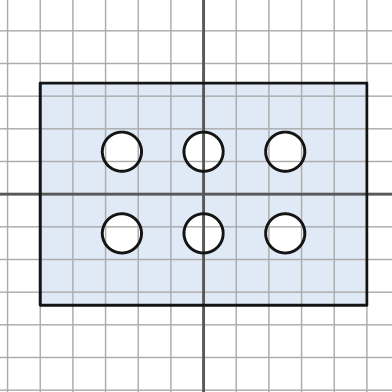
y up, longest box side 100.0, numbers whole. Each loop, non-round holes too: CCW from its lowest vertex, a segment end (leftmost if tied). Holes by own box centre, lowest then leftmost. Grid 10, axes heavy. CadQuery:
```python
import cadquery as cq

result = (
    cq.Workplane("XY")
    .moveTo(-50.0, -34.0)
    .lineTo(50.0, -34.0)
    .lineTo(50.0, 34.0)
    .lineTo(-50.0, 34.0)
    .close()
    .moveTo(-25.0, -12.0)
    .circle(6.0)
    .moveTo(0.0, -12.0)
    .circle(6.0)
    .moveTo(25.0, -12.0)
    .circle(6.0)
    .moveTo(-25.0, 13.0)
    .circle(6.0)
    .moveTo(0.0, 13.0)
    .circle(6.0)
    .moveTo(25.0, 13.0)
    .circle(6.0)
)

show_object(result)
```